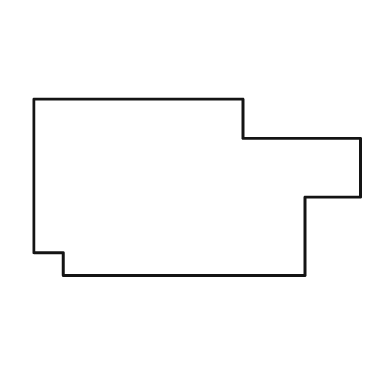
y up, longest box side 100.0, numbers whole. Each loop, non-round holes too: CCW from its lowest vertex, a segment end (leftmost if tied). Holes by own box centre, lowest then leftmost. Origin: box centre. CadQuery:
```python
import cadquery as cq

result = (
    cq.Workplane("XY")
    .moveTo(-41.0, -27.0)
    .lineTo(33.0, -27.0)
    .lineTo(33.0, -3.0)
    .lineTo(50.0, -3.0)
    .lineTo(50.0, 15.0)
    .lineTo(14.0, 15.0)
    .lineTo(14.0, 27.0)
    .lineTo(-50.0, 27.0)
    .lineTo(-50.0, -20.0)
    .lineTo(-41.0, -20.0)
    .close()
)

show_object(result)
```